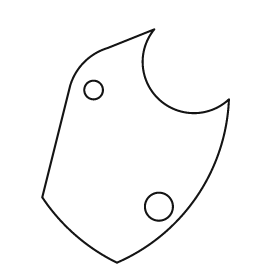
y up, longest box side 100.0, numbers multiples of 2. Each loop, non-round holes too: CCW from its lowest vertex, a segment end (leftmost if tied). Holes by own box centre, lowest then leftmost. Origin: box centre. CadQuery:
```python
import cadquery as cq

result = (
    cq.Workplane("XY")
    .moveTo(-8.0, -50.0)
    .threePointArc((26.0, -22.0), (40.0, 20.0))
    .threePointArc((10.0, 20.0), (8.0, 50.0))
    .lineTo(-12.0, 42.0)
    .threePointArc((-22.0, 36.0), (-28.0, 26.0))
    .lineTo(-40.0, -22.0)
    .threePointArc((-26.0, -38.0), (-8.0, -50.0))
    .close()
    .moveTo(10.0, -26.0)
    .circle(6.0)
    .moveTo(-18.0, 24.0)
    .circle(4.0)
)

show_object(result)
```